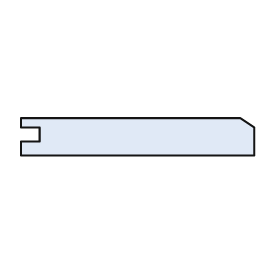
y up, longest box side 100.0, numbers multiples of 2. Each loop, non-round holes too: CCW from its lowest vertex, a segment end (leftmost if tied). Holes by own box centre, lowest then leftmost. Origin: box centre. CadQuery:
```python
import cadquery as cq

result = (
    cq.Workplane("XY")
    .moveTo(-50.0, -8.0)
    .lineTo(50.0, -8.0)
    .lineTo(50.0, 4.0)
    .lineTo(44.0, 8.0)
    .lineTo(-50.0, 8.0)
    .lineTo(-50.0, 4.0)
    .lineTo(-42.0, 4.0)
    .lineTo(-42.0, -2.0)
    .lineTo(-50.0, -2.0)
    .close()
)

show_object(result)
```